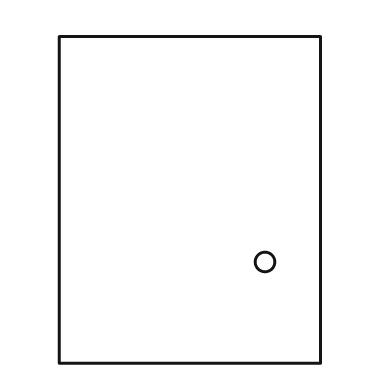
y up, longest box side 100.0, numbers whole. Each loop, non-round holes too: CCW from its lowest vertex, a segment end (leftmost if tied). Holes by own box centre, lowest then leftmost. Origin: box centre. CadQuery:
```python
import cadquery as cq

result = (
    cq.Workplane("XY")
    .moveTo(-40.0, -50.0)
    .lineTo(40.0, -50.0)
    .lineTo(40.0, 50.0)
    .lineTo(-40.0, 50.0)
    .close()
    .moveTo(23.0, -19.0)
    .circle(3.0)
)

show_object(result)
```